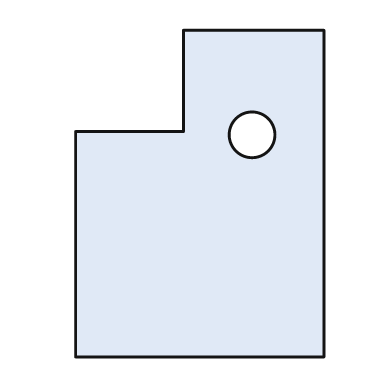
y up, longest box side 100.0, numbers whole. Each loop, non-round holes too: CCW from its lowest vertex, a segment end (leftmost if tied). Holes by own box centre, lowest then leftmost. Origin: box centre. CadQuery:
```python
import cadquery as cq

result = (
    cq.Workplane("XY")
    .moveTo(-38.0, -50.0)
    .lineTo(38.0, -50.0)
    .lineTo(38.0, 50.0)
    .lineTo(-5.0, 50.0)
    .lineTo(-5.0, 19.0)
    .lineTo(-38.0, 19.0)
    .close()
    .moveTo(16.0, 18.0)
    .circle(7.0)
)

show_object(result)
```